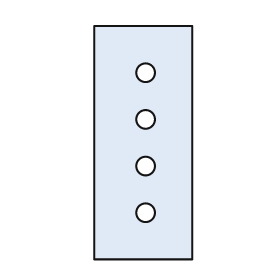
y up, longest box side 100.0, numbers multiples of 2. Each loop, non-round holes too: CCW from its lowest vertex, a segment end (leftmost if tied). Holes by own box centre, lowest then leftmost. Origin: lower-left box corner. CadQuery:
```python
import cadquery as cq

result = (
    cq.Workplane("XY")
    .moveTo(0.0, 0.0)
    .lineTo(42.0, 0.0)
    .lineTo(42.0, 100.0)
    .lineTo(0.0, 100.0)
    .close()
    .moveTo(22.0, 20.0)
    .circle(4.0)
    .moveTo(22.0, 40.0)
    .circle(4.0)
    .moveTo(22.0, 60.0)
    .circle(4.0)
    .moveTo(22.0, 80.0)
    .circle(4.0)
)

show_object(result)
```